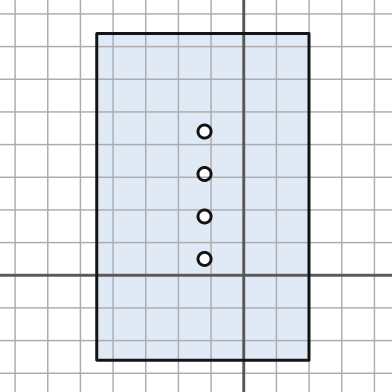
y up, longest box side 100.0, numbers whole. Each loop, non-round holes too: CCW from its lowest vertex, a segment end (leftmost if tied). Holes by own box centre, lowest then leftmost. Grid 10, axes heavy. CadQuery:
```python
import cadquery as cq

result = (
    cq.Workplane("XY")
    .moveTo(-45.0, -26.0)
    .lineTo(20.0, -26.0)
    .lineTo(20.0, 74.0)
    .lineTo(-45.0, 74.0)
    .close()
    .moveTo(-12.0, 5.0)
    .circle(2.0)
    .moveTo(-12.0, 18.0)
    .circle(2.0)
    .moveTo(-12.0, 31.0)
    .circle(2.0)
    .moveTo(-12.0, 44.0)
    .circle(2.0)
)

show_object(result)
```